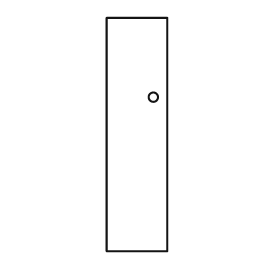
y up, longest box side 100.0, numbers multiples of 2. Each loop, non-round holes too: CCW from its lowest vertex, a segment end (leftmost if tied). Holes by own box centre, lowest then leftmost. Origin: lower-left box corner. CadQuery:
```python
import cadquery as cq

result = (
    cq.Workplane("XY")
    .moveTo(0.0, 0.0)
    .lineTo(26.0, 0.0)
    .lineTo(26.0, 100.0)
    .lineTo(0.0, 100.0)
    .close()
    .moveTo(20.0, 66.0)
    .circle(2.0)
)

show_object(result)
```